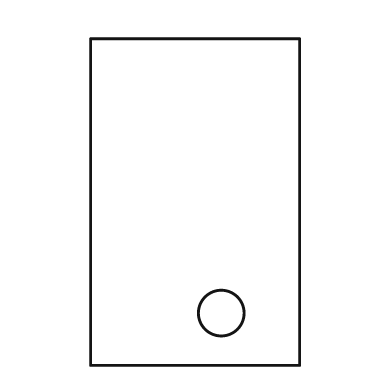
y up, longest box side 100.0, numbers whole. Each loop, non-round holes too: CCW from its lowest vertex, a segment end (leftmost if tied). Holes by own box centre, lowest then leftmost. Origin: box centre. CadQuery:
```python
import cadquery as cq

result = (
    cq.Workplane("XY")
    .moveTo(-32.0, -50.0)
    .lineTo(32.0, -50.0)
    .lineTo(32.0, 50.0)
    .lineTo(-32.0, 50.0)
    .close()
    .moveTo(8.0, -34.0)
    .circle(7.0)
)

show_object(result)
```